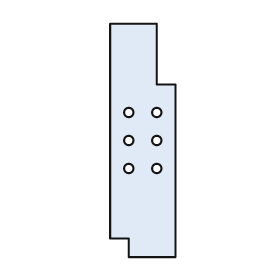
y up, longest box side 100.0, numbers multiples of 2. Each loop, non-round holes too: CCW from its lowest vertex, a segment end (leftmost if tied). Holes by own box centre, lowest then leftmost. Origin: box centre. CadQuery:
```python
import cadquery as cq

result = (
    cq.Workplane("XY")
    .moveTo(-6.0, -50.0)
    .lineTo(14.0, -50.0)
    .lineTo(14.0, 24.0)
    .lineTo(6.0, 24.0)
    .lineTo(6.0, 50.0)
    .lineTo(-14.0, 50.0)
    .lineTo(-14.0, -42.0)
    .lineTo(-6.0, -42.0)
    .close()
    .moveTo(-6.0, -12.0)
    .circle(2.0)
    .moveTo(6.0, -12.0)
    .circle(2.0)
    .moveTo(-6.0, 0.0)
    .circle(2.0)
    .moveTo(6.0, 0.0)
    .circle(2.0)
    .moveTo(-6.0, 12.0)
    .circle(2.0)
    .moveTo(6.0, 12.0)
    .circle(2.0)
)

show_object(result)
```